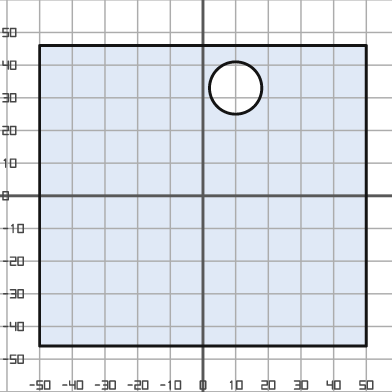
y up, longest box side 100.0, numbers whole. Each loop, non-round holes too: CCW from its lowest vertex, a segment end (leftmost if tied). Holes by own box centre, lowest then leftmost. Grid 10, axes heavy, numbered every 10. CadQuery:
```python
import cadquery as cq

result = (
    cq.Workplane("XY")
    .moveTo(-50.0, -46.0)
    .lineTo(50.0, -46.0)
    .lineTo(50.0, 46.0)
    .lineTo(-50.0, 46.0)
    .close()
    .moveTo(10.0, 33.0)
    .circle(8.0)
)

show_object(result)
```